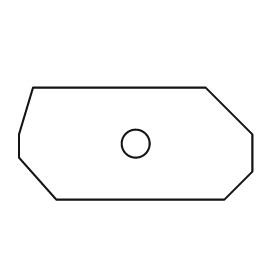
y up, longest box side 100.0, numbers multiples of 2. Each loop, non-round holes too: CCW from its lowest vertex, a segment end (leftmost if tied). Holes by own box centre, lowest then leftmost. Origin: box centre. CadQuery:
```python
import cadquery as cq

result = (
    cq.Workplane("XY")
    .moveTo(-34.0, -24.0)
    .lineTo(38.0, -24.0)
    .lineTo(50.0, -12.0)
    .lineTo(50.0, 4.0)
    .lineTo(30.0, 24.0)
    .lineTo(-44.0, 24.0)
    .lineTo(-50.0, 4.0)
    .lineTo(-50.0, -6.0)
    .close()
    .moveTo(0.0, 0.0)
    .circle(6.0)
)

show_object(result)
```